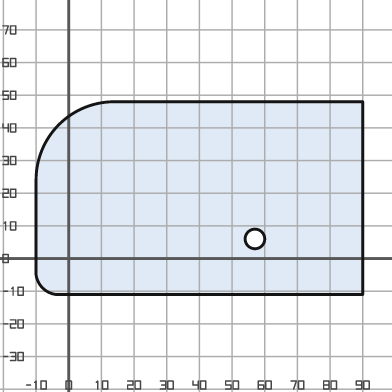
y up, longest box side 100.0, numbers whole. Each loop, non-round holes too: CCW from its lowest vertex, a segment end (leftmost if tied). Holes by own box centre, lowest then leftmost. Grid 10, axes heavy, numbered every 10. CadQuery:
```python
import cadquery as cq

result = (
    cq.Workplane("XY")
    .moveTo(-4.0, -11.0)
    .lineTo(90.0, -11.0)
    .lineTo(90.0, 48.0)
    .lineTo(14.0, 48.0)
    .threePointArc((-3.0, 41.0), (-10.0, 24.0))
    .lineTo(-10.0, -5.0)
    .threePointArc((-8.0, -9.0), (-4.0, -11.0))
    .close()
    .moveTo(57.0, 6.0)
    .circle(3.0)
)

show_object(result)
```